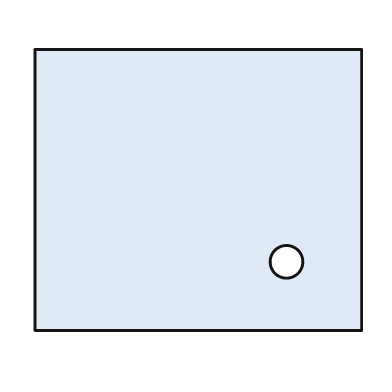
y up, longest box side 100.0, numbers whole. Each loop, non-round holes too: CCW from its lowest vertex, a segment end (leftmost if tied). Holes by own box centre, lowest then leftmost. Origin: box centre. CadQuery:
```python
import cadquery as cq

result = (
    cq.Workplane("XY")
    .moveTo(-50.0, -43.0)
    .lineTo(50.0, -43.0)
    .lineTo(50.0, 43.0)
    .lineTo(-50.0, 43.0)
    .close()
    .moveTo(27.0, -22.0)
    .circle(5.0)
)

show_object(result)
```